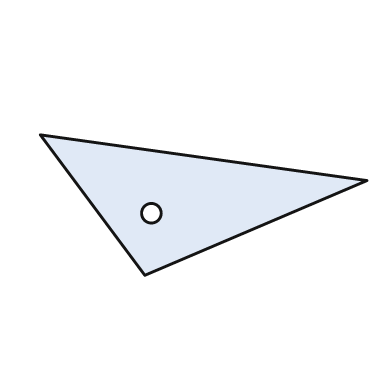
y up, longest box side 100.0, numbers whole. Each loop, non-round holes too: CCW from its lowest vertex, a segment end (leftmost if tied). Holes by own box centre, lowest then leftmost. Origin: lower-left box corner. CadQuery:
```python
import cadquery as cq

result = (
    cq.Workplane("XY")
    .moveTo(32.0, 0.0)
    .lineTo(100.0, 29.0)
    .lineTo(0.0, 43.0)
    .close()
    .moveTo(34.0, 19.0)
    .circle(3.0)
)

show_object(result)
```